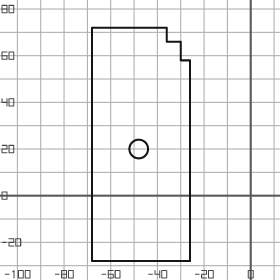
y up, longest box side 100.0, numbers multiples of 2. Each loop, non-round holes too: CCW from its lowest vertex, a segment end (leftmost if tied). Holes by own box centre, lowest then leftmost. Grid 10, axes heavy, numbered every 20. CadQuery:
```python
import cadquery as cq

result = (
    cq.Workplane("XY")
    .moveTo(-68.0, -28.0)
    .lineTo(-26.0, -28.0)
    .lineTo(-26.0, 58.0)
    .lineTo(-30.0, 58.0)
    .lineTo(-30.0, 66.0)
    .lineTo(-36.0, 66.0)
    .lineTo(-36.0, 72.0)
    .lineTo(-68.0, 72.0)
    .close()
    .moveTo(-48.0, 20.0)
    .circle(4.0)
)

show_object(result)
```